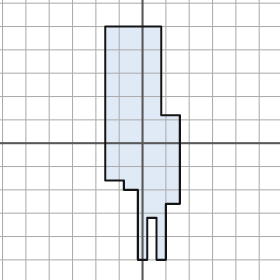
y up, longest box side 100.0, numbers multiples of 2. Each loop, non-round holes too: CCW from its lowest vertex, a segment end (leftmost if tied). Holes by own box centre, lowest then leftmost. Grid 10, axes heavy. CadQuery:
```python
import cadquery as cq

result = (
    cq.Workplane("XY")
    .moveTo(-2.0, -50.0)
    .lineTo(2.0, -50.0)
    .lineTo(2.0, -32.0)
    .lineTo(6.0, -32.0)
    .lineTo(6.0, -50.0)
    .lineTo(10.0, -50.0)
    .lineTo(10.0, -26.0)
    .lineTo(16.0, -26.0)
    .lineTo(16.0, 12.0)
    .lineTo(8.0, 12.0)
    .lineTo(8.0, 50.0)
    .lineTo(-16.0, 50.0)
    .lineTo(-16.0, -16.0)
    .lineTo(-8.0, -16.0)
    .lineTo(-8.0, -20.0)
    .lineTo(-2.0, -20.0)
    .close()
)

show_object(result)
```